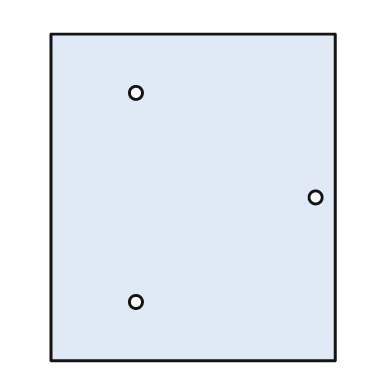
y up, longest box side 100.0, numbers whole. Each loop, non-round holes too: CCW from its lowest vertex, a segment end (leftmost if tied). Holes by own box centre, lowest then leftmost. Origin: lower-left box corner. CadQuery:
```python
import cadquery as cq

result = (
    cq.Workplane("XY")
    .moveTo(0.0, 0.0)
    .lineTo(87.0, 0.0)
    .lineTo(87.0, 100.0)
    .lineTo(0.0, 100.0)
    .close()
    .moveTo(26.0, 18.0)
    .circle(2.0)
    .moveTo(81.0, 50.0)
    .circle(2.0)
    .moveTo(26.0, 82.0)
    .circle(2.0)
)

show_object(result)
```